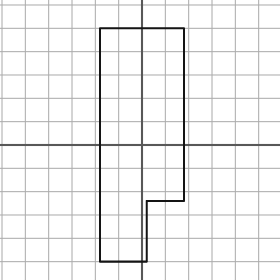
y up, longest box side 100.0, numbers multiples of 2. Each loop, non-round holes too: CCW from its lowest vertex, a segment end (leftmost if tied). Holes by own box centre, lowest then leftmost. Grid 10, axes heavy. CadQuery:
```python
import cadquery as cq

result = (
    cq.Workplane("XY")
    .moveTo(-18.0, -50.0)
    .lineTo(2.0, -50.0)
    .lineTo(2.0, -24.0)
    .lineTo(18.0, -24.0)
    .lineTo(18.0, 50.0)
    .lineTo(-18.0, 50.0)
    .close()
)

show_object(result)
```